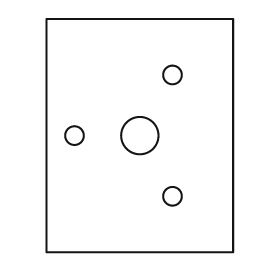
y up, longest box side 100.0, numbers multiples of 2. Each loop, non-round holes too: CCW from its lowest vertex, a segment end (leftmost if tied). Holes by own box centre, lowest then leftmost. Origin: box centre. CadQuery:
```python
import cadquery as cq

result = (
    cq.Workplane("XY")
    .moveTo(-40.0, -50.0)
    .lineTo(40.0, -50.0)
    .lineTo(40.0, 50.0)
    .lineTo(-40.0, 50.0)
    .close()
    .moveTo(14.0, -26.0)
    .circle(4.0)
    .moveTo(-28.0, 0.0)
    .circle(4.0)
    .moveTo(0.0, 0.0)
    .circle(8.0)
    .moveTo(14.0, 26.0)
    .circle(4.0)
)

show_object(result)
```